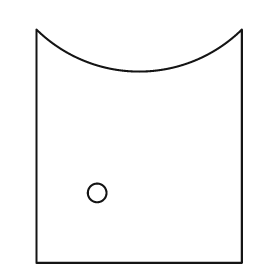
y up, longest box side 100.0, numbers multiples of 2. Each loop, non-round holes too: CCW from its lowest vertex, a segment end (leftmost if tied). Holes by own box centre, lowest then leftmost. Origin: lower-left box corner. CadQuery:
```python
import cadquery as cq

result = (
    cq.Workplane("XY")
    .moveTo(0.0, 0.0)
    .lineTo(88.0, 0.0)
    .lineTo(88.0, 100.0)
    .threePointArc((44.0, 82.0), (0.0, 100.0))
    .close()
    .moveTo(26.0, 30.0)
    .circle(4.0)
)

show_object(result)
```